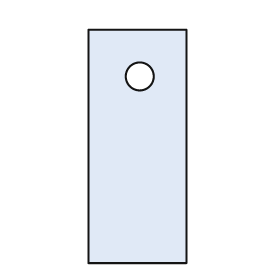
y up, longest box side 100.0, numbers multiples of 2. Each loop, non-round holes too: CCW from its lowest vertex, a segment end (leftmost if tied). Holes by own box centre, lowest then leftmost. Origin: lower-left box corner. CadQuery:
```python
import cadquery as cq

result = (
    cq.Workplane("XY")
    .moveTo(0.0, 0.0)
    .lineTo(42.0, 0.0)
    .lineTo(42.0, 100.0)
    .lineTo(0.0, 100.0)
    .close()
    .moveTo(22.0, 80.0)
    .circle(6.0)
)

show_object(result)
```